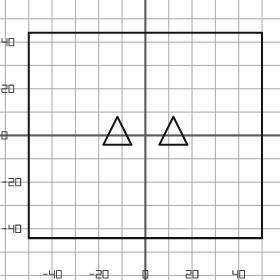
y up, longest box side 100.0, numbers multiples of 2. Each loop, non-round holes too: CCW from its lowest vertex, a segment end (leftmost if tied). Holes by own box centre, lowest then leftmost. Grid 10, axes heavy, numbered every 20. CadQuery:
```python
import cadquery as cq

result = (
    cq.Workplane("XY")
    .moveTo(-50.0, -44.0)
    .lineTo(50.0, -44.0)
    .lineTo(50.0, 44.0)
    .lineTo(-50.0, 44.0)
    .close()
    .moveTo(-18.0, -4.0)
    .lineTo(-6.0, -4.0)
    .lineTo(-12.0, 8.0)
    .close()
    .moveTo(6.0, -4.0)
    .lineTo(18.0, -4.0)
    .lineTo(12.0, 8.0)
    .close()
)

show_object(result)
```